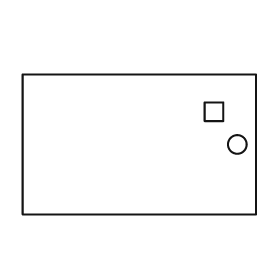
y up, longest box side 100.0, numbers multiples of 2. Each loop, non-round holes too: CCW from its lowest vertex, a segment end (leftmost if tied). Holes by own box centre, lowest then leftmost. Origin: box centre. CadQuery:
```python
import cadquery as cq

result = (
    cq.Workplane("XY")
    .moveTo(-50.0, -30.0)
    .lineTo(50.0, -30.0)
    .lineTo(50.0, 30.0)
    .lineTo(-50.0, 30.0)
    .close()
    .moveTo(42.0, 0.0)
    .circle(4.0)
    .moveTo(28.0, 10.0)
    .lineTo(36.0, 10.0)
    .lineTo(36.0, 18.0)
    .lineTo(28.0, 18.0)
    .close()
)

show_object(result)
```